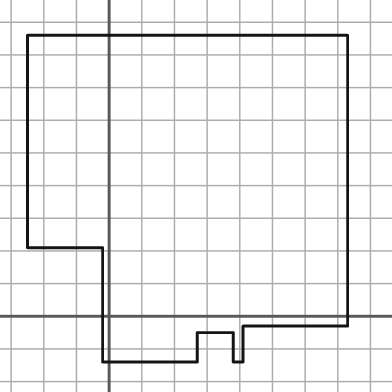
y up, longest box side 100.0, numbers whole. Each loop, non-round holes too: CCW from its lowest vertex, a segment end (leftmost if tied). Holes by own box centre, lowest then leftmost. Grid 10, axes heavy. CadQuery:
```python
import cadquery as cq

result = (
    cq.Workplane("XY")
    .moveTo(-2.0, -14.0)
    .lineTo(27.0, -14.0)
    .lineTo(27.0, -5.0)
    .lineTo(38.0, -5.0)
    .lineTo(38.0, -14.0)
    .lineTo(41.0, -14.0)
    .lineTo(41.0, -3.0)
    .lineTo(73.0, -3.0)
    .lineTo(73.0, 86.0)
    .lineTo(-25.0, 86.0)
    .lineTo(-25.0, 21.0)
    .lineTo(-2.0, 21.0)
    .close()
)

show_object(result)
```